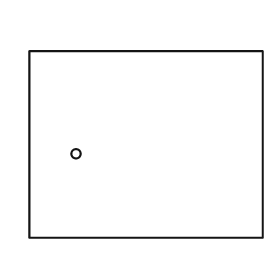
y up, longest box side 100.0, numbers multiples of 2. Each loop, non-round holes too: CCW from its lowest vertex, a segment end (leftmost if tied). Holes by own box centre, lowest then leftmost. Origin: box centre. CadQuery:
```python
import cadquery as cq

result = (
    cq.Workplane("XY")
    .moveTo(-50.0, -40.0)
    .lineTo(50.0, -40.0)
    .lineTo(50.0, 40.0)
    .lineTo(-50.0, 40.0)
    .close()
    .moveTo(-30.0, -4.0)
    .circle(2.0)
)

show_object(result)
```